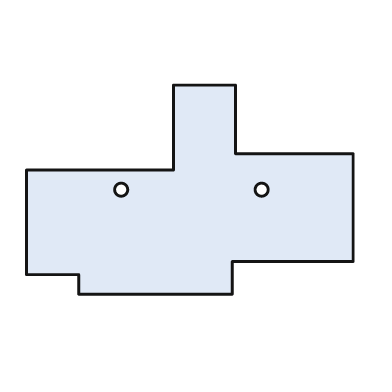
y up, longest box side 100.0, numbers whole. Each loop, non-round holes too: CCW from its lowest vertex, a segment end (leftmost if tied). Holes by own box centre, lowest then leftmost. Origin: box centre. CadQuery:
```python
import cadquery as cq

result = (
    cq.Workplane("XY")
    .moveTo(-34.0, -32.0)
    .lineTo(13.0, -32.0)
    .lineTo(13.0, -22.0)
    .lineTo(50.0, -22.0)
    .lineTo(50.0, 11.0)
    .lineTo(14.0, 11.0)
    .lineTo(14.0, 32.0)
    .lineTo(-5.0, 32.0)
    .lineTo(-5.0, 6.0)
    .lineTo(-50.0, 6.0)
    .lineTo(-50.0, -26.0)
    .lineTo(-34.0, -26.0)
    .close()
    .moveTo(-21.0, 0.0)
    .circle(2.0)
    .moveTo(22.0, 0.0)
    .circle(2.0)
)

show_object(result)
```